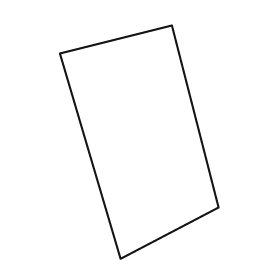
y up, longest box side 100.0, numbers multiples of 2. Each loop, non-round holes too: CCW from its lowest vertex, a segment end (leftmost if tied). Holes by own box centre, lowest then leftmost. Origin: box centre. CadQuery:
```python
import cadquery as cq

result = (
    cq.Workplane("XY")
    .moveTo(-8.0, -50.0)
    .lineTo(34.0, -28.0)
    .lineTo(14.0, 50.0)
    .lineTo(-34.0, 38.0)
    .close()
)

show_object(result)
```